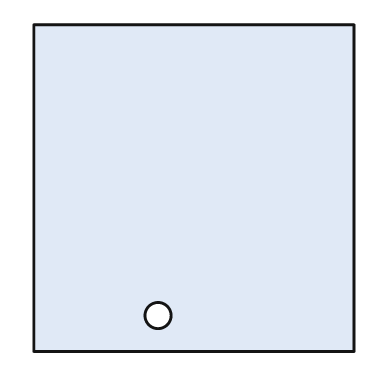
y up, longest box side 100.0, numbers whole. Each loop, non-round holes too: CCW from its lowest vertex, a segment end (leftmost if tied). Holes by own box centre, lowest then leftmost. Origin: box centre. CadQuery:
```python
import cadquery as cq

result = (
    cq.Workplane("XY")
    .moveTo(-49.0, -50.0)
    .lineTo(49.0, -50.0)
    .lineTo(49.0, 50.0)
    .lineTo(-49.0, 50.0)
    .close()
    .moveTo(-11.0, -39.0)
    .circle(4.0)
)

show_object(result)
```